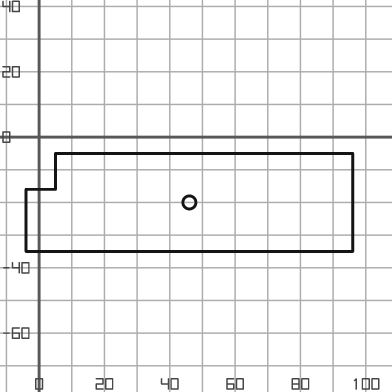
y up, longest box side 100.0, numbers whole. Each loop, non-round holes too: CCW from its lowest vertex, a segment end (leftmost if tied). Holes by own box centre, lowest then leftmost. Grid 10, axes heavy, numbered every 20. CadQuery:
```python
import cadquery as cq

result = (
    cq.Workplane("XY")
    .moveTo(-4.0, -35.0)
    .lineTo(96.0, -35.0)
    .lineTo(96.0, -5.0)
    .lineTo(5.0, -5.0)
    .lineTo(5.0, -16.0)
    .lineTo(-4.0, -16.0)
    .close()
    .moveTo(46.0, -20.0)
    .circle(2.0)
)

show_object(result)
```